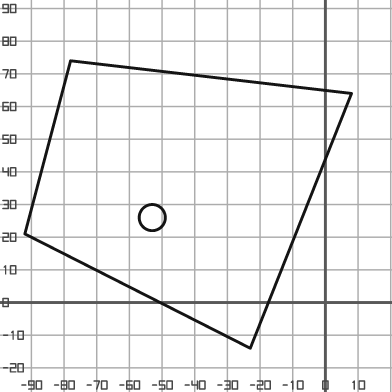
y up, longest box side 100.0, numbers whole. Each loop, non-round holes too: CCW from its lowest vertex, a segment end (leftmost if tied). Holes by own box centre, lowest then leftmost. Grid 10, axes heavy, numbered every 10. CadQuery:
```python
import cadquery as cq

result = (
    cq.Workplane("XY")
    .moveTo(-23.0, -14.0)
    .lineTo(8.0, 64.0)
    .lineTo(-78.0, 74.0)
    .lineTo(-92.0, 21.0)
    .close()
    .moveTo(-53.0, 26.0)
    .circle(4.0)
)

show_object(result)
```